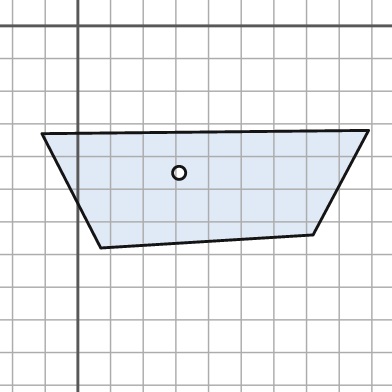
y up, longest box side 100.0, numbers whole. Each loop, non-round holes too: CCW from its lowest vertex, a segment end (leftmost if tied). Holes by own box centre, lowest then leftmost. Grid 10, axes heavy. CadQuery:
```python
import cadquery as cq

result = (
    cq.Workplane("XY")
    .moveTo(7.0, -68.0)
    .lineTo(72.0, -64.0)
    .lineTo(89.0, -32.0)
    .lineTo(-11.0, -33.0)
    .close()
    .moveTo(31.0, -45.0)
    .circle(2.0)
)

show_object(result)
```